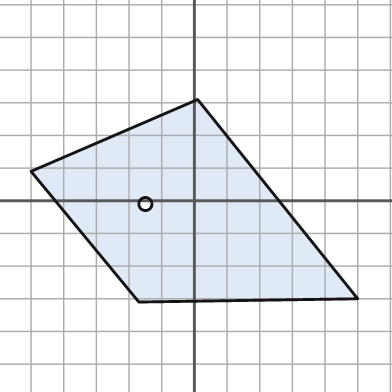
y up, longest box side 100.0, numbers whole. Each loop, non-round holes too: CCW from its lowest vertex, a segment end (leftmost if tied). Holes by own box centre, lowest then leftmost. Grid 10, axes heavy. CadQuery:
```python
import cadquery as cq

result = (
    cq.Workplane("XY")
    .moveTo(-17.0, -31.0)
    .lineTo(50.0, -30.0)
    .lineTo(1.0, 31.0)
    .lineTo(-50.0, 9.0)
    .close()
    .moveTo(-15.0, -1.0)
    .circle(2.0)
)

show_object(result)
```